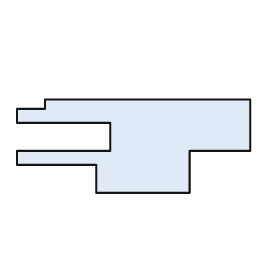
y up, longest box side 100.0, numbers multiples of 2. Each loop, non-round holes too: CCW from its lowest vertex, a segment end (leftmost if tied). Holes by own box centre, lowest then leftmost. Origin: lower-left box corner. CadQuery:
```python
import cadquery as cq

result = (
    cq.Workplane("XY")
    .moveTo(34.0, 0.0)
    .lineTo(74.0, 0.0)
    .lineTo(74.0, 18.0)
    .lineTo(100.0, 18.0)
    .lineTo(100.0, 40.0)
    .lineTo(12.0, 40.0)
    .lineTo(12.0, 36.0)
    .lineTo(0.0, 36.0)
    .lineTo(0.0, 30.0)
    .lineTo(40.0, 30.0)
    .lineTo(40.0, 18.0)
    .lineTo(0.0, 18.0)
    .lineTo(0.0, 12.0)
    .lineTo(34.0, 12.0)
    .close()
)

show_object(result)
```